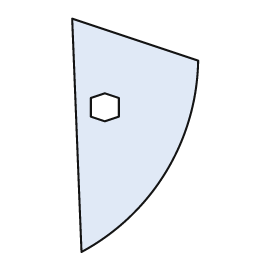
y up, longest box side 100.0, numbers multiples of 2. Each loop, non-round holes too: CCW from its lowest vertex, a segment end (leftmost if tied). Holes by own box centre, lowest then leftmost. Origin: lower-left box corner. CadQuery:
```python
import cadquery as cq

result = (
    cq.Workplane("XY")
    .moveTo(4.0, 0.0)
    .threePointArc((40.0, 34.0), (54.0, 82.0))
    .lineTo(0.0, 100.0)
    .close()
    .moveTo(14.0, 56.0)
    .lineTo(20.0, 58.0)
    .lineTo(20.0, 66.0)
    .lineTo(14.0, 68.0)
    .lineTo(8.0, 66.0)
    .lineTo(8.0, 58.0)
    .close()
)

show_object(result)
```